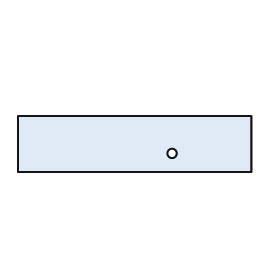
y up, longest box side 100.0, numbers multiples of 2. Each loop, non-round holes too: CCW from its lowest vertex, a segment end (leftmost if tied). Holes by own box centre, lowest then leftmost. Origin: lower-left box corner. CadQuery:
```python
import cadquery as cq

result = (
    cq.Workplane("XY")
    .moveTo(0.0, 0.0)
    .lineTo(100.0, 0.0)
    .lineTo(100.0, 24.0)
    .lineTo(0.0, 24.0)
    .close()
    .moveTo(66.0, 8.0)
    .circle(2.0)
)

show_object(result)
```